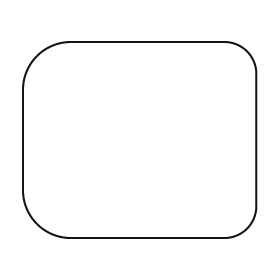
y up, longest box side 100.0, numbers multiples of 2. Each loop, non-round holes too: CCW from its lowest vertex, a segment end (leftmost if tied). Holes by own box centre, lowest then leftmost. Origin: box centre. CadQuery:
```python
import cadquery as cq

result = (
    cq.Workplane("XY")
    .moveTo(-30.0, -42.0)
    .lineTo(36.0, -42.0)
    .threePointArc((46.0, -38.0), (50.0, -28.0))
    .lineTo(50.0, 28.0)
    .threePointArc((46.0, 38.0), (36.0, 42.0))
    .lineTo(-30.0, 42.0)
    .threePointArc((-44.0, 36.0), (-50.0, 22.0))
    .lineTo(-50.0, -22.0)
    .threePointArc((-44.0, -36.0), (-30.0, -42.0))
    .close()
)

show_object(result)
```